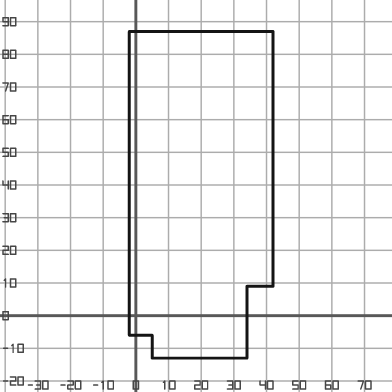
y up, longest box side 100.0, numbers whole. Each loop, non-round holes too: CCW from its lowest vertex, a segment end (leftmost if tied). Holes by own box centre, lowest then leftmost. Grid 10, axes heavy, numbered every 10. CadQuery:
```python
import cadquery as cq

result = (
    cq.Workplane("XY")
    .moveTo(5.0, -13.0)
    .lineTo(34.0, -13.0)
    .lineTo(34.0, 9.0)
    .lineTo(42.0, 9.0)
    .lineTo(42.0, 87.0)
    .lineTo(-2.0, 87.0)
    .lineTo(-2.0, -6.0)
    .lineTo(5.0, -6.0)
    .close()
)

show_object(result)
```